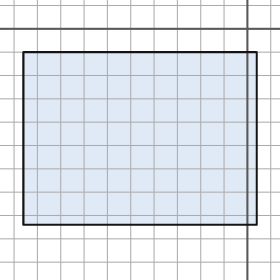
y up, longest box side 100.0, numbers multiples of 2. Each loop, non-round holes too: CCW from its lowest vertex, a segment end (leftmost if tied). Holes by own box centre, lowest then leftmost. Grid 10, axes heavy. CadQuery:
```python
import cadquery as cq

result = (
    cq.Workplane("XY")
    .moveTo(-96.0, -84.0)
    .lineTo(4.0, -84.0)
    .lineTo(4.0, -10.0)
    .lineTo(-96.0, -10.0)
    .close()
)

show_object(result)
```